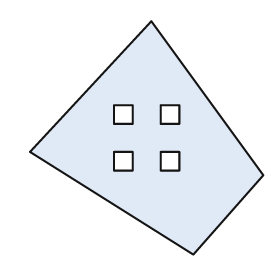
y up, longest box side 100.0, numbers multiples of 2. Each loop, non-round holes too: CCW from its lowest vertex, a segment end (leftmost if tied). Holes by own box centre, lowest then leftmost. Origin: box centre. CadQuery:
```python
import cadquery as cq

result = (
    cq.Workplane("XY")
    .moveTo(20.0, -50.0)
    .lineTo(50.0, -16.0)
    .lineTo(2.0, 50.0)
    .lineTo(-50.0, -6.0)
    .close()
    .moveTo(-14.0, -14.0)
    .lineTo(-6.0, -14.0)
    .lineTo(-6.0, -6.0)
    .lineTo(-14.0, -6.0)
    .close()
    .moveTo(6.0, -14.0)
    .lineTo(14.0, -14.0)
    .lineTo(14.0, -6.0)
    .lineTo(6.0, -6.0)
    .close()
    .moveTo(-14.0, 6.0)
    .lineTo(-6.0, 6.0)
    .lineTo(-6.0, 14.0)
    .lineTo(-14.0, 14.0)
    .close()
    .moveTo(6.0, 6.0)
    .lineTo(14.0, 6.0)
    .lineTo(14.0, 14.0)
    .lineTo(6.0, 14.0)
    .close()
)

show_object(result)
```